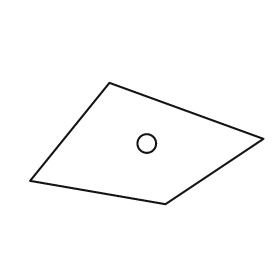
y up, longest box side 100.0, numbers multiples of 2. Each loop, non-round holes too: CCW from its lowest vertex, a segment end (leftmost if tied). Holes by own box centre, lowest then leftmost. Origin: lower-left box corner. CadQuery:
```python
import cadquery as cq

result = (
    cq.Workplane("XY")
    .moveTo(58.0, 0.0)
    .lineTo(100.0, 28.0)
    .lineTo(34.0, 52.0)
    .lineTo(0.0, 10.0)
    .close()
    .moveTo(50.0, 26.0)
    .circle(4.0)
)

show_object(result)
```